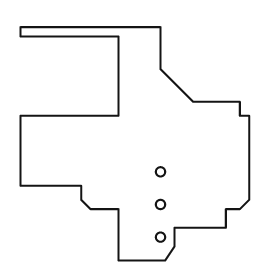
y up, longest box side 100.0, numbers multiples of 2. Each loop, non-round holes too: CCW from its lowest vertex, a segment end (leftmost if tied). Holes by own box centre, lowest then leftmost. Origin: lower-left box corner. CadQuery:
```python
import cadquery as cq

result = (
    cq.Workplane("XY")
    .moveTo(42.0, 0.0)
    .lineTo(62.0, 0.0)
    .lineTo(66.0, 6.0)
    .lineTo(66.0, 14.0)
    .lineTo(88.0, 14.0)
    .lineTo(88.0, 22.0)
    .lineTo(94.0, 22.0)
    .lineTo(98.0, 26.0)
    .lineTo(98.0, 62.0)
    .lineTo(94.0, 62.0)
    .lineTo(94.0, 68.0)
    .lineTo(74.0, 68.0)
    .lineTo(60.0, 82.0)
    .lineTo(60.0, 100.0)
    .lineTo(0.0, 100.0)
    .lineTo(0.0, 96.0)
    .lineTo(42.0, 96.0)
    .lineTo(42.0, 62.0)
    .lineTo(0.0, 62.0)
    .lineTo(0.0, 32.0)
    .lineTo(26.0, 32.0)
    .lineTo(26.0, 26.0)
    .lineTo(30.0, 22.0)
    .lineTo(42.0, 22.0)
    .close()
    .moveTo(60.0, 10.0)
    .circle(2.0)
    .moveTo(60.0, 24.0)
    .circle(2.0)
    .moveTo(60.0, 38.0)
    .circle(2.0)
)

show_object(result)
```